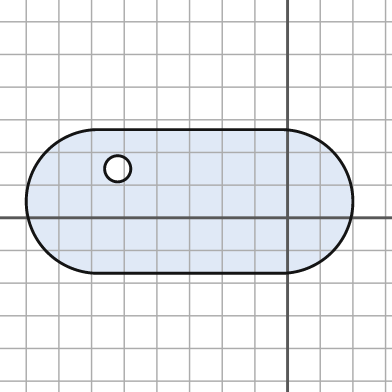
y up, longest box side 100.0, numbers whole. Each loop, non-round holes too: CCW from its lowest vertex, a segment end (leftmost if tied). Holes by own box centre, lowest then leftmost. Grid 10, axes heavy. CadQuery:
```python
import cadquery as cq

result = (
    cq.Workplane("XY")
    .moveTo(-58.0, -17.0)
    .lineTo(-2.0, -17.0)
    .threePointArc((20.0, 5.0), (-2.0, 27.0))
    .lineTo(-58.0, 27.0)
    .threePointArc((-80.0, 5.0), (-58.0, -17.0))
    .close()
    .moveTo(-52.0, 15.0)
    .circle(4.0)
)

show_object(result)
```